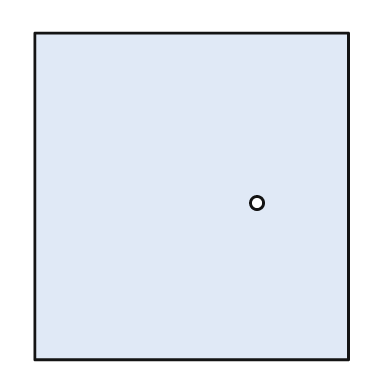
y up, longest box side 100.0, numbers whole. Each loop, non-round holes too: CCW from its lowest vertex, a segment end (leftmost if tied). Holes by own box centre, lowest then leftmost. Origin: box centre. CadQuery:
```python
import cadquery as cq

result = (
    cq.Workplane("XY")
    .moveTo(-48.0, -50.0)
    .lineTo(48.0, -50.0)
    .lineTo(48.0, 50.0)
    .lineTo(-48.0, 50.0)
    .close()
    .moveTo(20.0, -2.0)
    .circle(2.0)
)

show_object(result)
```